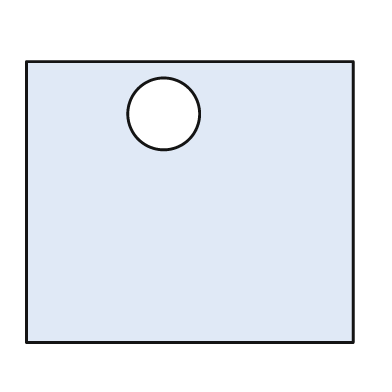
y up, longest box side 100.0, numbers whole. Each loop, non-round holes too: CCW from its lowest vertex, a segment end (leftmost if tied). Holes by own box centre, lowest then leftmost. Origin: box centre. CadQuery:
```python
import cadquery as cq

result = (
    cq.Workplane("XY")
    .moveTo(-50.0, -43.0)
    .lineTo(50.0, -43.0)
    .lineTo(50.0, 43.0)
    .lineTo(-50.0, 43.0)
    .close()
    .moveTo(-8.0, 27.0)
    .circle(11.0)
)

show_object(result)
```